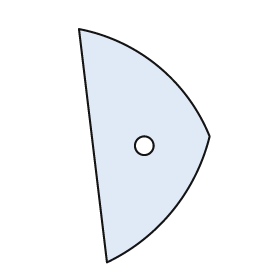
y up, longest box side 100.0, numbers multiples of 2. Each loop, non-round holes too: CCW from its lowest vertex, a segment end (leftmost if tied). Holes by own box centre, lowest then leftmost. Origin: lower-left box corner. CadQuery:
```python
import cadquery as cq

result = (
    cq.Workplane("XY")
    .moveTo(12.0, 0.0)
    .threePointArc((40.0, 22.0), (56.0, 54.0))
    .threePointArc((34.0, 84.0), (0.0, 100.0))
    .close()
    .moveTo(28.0, 50.0)
    .circle(4.0)
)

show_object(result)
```